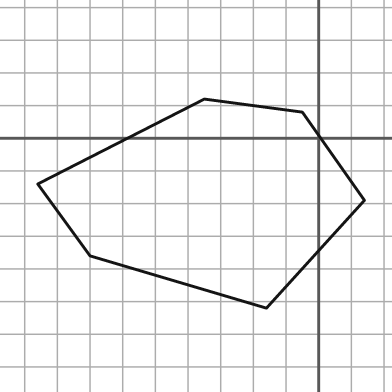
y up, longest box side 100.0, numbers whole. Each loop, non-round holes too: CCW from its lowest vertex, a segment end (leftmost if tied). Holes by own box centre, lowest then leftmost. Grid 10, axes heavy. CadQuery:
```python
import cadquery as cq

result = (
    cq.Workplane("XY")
    .moveTo(-16.0, -52.0)
    .lineTo(14.0, -19.0)
    .lineTo(-5.0, 8.0)
    .lineTo(-35.0, 12.0)
    .lineTo(-86.0, -14.0)
    .lineTo(-70.0, -36.0)
    .close()
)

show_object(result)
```